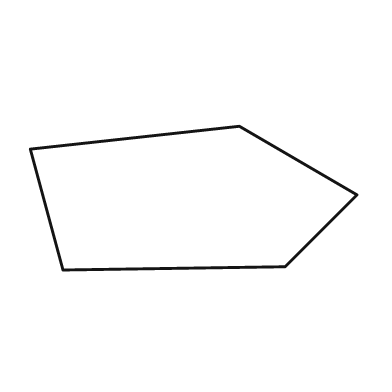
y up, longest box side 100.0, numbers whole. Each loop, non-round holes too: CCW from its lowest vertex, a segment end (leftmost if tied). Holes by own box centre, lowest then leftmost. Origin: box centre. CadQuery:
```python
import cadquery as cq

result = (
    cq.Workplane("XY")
    .moveTo(-40.0, -22.0)
    .lineTo(28.0, -21.0)
    .lineTo(50.0, 1.0)
    .lineTo(14.0, 22.0)
    .lineTo(-50.0, 15.0)
    .close()
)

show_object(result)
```